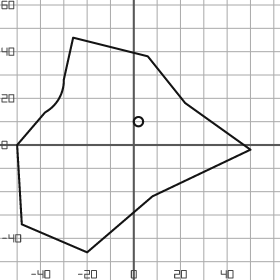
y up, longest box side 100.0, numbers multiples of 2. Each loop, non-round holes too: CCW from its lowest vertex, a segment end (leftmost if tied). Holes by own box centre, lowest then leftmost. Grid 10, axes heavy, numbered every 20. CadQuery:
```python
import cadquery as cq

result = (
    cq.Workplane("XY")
    .moveTo(-20.0, -46.0)
    .lineTo(8.0, -22.0)
    .lineTo(50.0, -2.0)
    .lineTo(22.0, 18.0)
    .lineTo(6.0, 38.0)
    .lineTo(-26.0, 46.0)
    .lineTo(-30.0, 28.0)
    .threePointArc((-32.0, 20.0), (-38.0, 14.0))
    .lineTo(-50.0, 0.0)
    .lineTo(-48.0, -34.0)
    .close()
    .moveTo(2.0, 10.0)
    .circle(2.0)
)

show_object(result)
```